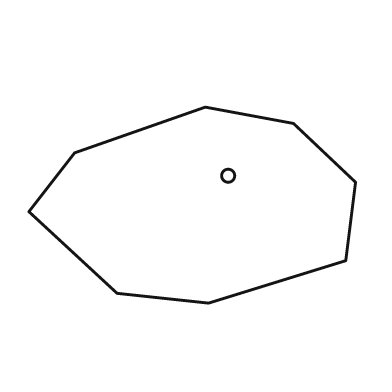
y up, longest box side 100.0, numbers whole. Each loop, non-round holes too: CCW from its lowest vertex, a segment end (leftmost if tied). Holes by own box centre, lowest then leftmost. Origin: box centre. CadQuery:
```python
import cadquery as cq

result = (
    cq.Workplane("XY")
    .moveTo(5.0, -30.0)
    .lineTo(47.0, -17.0)
    .lineTo(50.0, 7.0)
    .lineTo(31.0, 25.0)
    .lineTo(4.0, 30.0)
    .lineTo(-36.0, 16.0)
    .lineTo(-50.0, -2.0)
    .lineTo(-23.0, -27.0)
    .close()
    .moveTo(11.0, 9.0)
    .circle(2.0)
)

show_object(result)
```